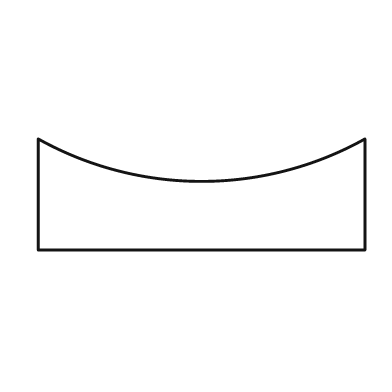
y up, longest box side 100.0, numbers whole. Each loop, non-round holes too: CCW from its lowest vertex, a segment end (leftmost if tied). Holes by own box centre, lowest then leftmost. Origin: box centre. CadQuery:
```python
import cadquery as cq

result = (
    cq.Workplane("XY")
    .moveTo(-50.0, -17.0)
    .lineTo(50.0, -17.0)
    .lineTo(50.0, 17.0)
    .threePointArc((0.0, 4.0), (-50.0, 17.0))
    .close()
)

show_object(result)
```